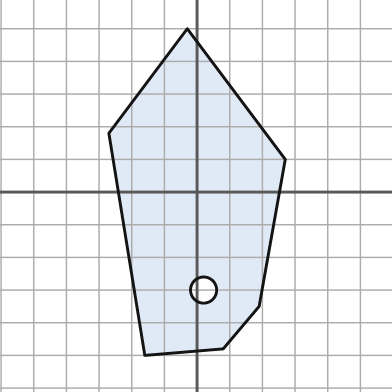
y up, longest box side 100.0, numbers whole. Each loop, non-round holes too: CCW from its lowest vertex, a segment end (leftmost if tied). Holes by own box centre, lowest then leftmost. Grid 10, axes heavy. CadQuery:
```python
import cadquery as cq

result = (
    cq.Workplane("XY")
    .moveTo(-16.0, -50.0)
    .lineTo(8.0, -48.0)
    .lineTo(19.0, -35.0)
    .lineTo(27.0, 10.0)
    .lineTo(-3.0, 50.0)
    .lineTo(-27.0, 18.0)
    .close()
    .moveTo(2.0, -30.0)
    .circle(4.0)
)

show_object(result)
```